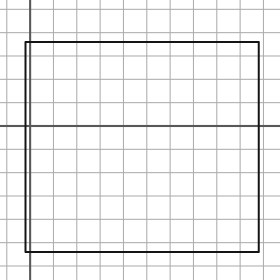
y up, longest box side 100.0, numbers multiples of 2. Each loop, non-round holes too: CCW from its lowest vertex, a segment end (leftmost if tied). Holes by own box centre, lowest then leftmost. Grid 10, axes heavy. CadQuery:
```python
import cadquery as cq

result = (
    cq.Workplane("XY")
    .moveTo(-2.0, -54.0)
    .lineTo(98.0, -54.0)
    .lineTo(98.0, 36.0)
    .lineTo(-2.0, 36.0)
    .close()
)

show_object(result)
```